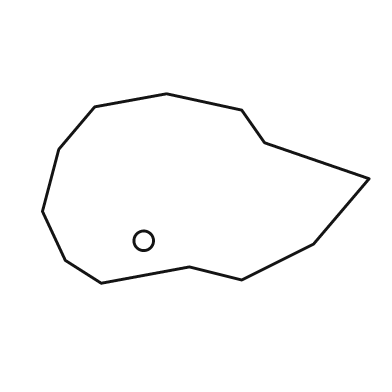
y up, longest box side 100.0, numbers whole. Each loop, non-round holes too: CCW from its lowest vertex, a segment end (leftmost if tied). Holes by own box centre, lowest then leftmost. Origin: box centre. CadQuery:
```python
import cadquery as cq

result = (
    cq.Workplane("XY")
    .moveTo(-32.0, -29.0)
    .lineTo(-5.0, -24.0)
    .lineTo(11.0, -28.0)
    .lineTo(33.0, -17.0)
    .lineTo(50.0, 3.0)
    .lineTo(18.0, 14.0)
    .lineTo(11.0, 24.0)
    .lineTo(-12.0, 29.0)
    .lineTo(-34.0, 25.0)
    .lineTo(-45.0, 12.0)
    .lineTo(-50.0, -7.0)
    .lineTo(-43.0, -22.0)
    .close()
    .moveTo(-19.0, -16.0)
    .circle(3.0)
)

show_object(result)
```